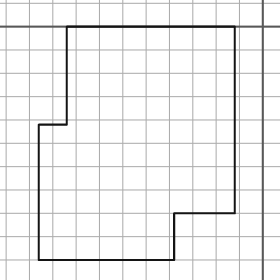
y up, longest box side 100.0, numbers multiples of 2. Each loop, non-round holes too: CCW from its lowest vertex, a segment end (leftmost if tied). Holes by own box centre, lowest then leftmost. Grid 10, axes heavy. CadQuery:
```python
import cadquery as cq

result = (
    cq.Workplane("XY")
    .moveTo(-96.0, -100.0)
    .lineTo(-38.0, -100.0)
    .lineTo(-38.0, -80.0)
    .lineTo(-12.0, -80.0)
    .lineTo(-12.0, 0.0)
    .lineTo(-84.0, 0.0)
    .lineTo(-84.0, -42.0)
    .lineTo(-96.0, -42.0)
    .close()
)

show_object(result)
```